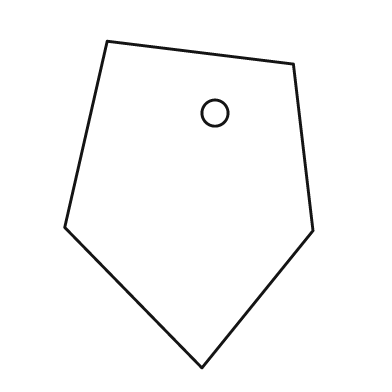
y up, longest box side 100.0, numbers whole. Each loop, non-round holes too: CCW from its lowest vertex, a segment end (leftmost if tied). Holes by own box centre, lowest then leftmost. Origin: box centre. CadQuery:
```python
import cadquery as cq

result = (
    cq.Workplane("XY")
    .moveTo(4.0, -50.0)
    .lineTo(38.0, -8.0)
    .lineTo(32.0, 43.0)
    .lineTo(-25.0, 50.0)
    .lineTo(-38.0, -7.0)
    .close()
    .moveTo(8.0, 28.0)
    .circle(4.0)
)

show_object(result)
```